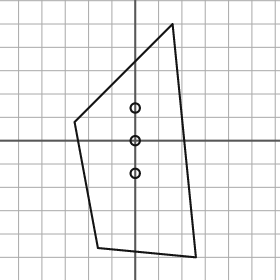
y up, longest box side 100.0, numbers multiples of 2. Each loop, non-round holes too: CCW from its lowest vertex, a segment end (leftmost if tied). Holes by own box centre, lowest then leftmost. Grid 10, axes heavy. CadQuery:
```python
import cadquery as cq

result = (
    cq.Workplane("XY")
    .moveTo(26.0, -50.0)
    .lineTo(16.0, 50.0)
    .lineTo(-26.0, 8.0)
    .lineTo(-16.0, -46.0)
    .close()
    .moveTo(0.0, -14.0)
    .circle(2.0)
    .moveTo(0.0, 0.0)
    .circle(2.0)
    .moveTo(0.0, 14.0)
    .circle(2.0)
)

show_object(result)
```